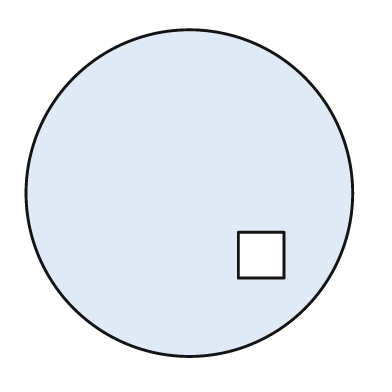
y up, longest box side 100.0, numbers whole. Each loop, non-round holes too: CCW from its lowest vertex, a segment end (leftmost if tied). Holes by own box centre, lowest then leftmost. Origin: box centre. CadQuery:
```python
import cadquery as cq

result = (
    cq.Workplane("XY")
    .moveTo(0.0, 0.0)
    .circle(50.0)
    .moveTo(15.0, -26.0)
    .lineTo(29.0, -26.0)
    .lineTo(29.0, -12.0)
    .lineTo(15.0, -12.0)
    .close()
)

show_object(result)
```